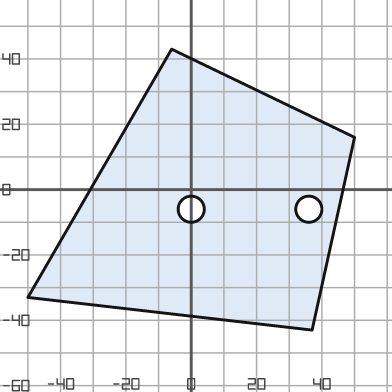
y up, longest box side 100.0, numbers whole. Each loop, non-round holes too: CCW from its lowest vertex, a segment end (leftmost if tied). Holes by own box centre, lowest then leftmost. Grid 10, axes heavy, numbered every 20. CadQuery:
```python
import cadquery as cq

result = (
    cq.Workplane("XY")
    .moveTo(37.0, -43.0)
    .lineTo(50.0, 16.0)
    .lineTo(-6.0, 43.0)
    .lineTo(-50.0, -33.0)
    .close()
    .moveTo(0.0, -6.0)
    .circle(4.0)
    .moveTo(36.0, -6.0)
    .circle(4.0)
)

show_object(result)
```